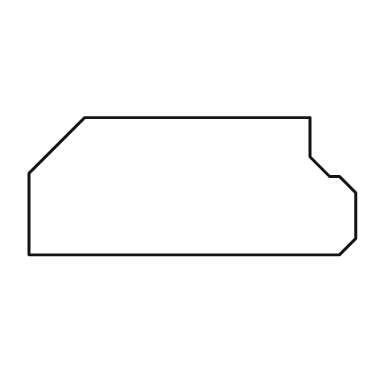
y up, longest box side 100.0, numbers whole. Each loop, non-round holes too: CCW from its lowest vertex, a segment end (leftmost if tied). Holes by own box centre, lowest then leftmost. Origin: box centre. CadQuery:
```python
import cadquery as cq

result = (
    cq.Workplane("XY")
    .moveTo(-50.0, -21.0)
    .lineTo(45.0, -21.0)
    .lineTo(50.0, -16.0)
    .lineTo(50.0, -2.0)
    .lineTo(45.0, 3.0)
    .lineTo(42.0, 3.0)
    .lineTo(36.0, 9.0)
    .lineTo(36.0, 21.0)
    .lineTo(-33.0, 21.0)
    .lineTo(-50.0, 4.0)
    .close()
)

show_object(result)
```